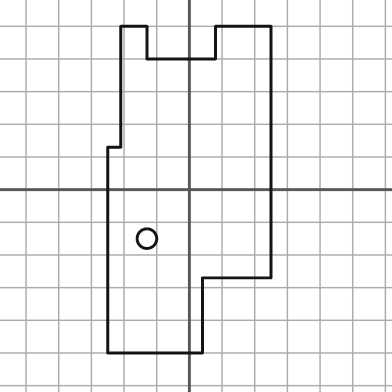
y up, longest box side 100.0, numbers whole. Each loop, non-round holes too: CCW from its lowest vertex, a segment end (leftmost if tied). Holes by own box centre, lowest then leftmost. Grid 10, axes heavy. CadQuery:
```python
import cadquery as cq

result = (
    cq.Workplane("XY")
    .moveTo(-25.0, -50.0)
    .lineTo(4.0, -50.0)
    .lineTo(4.0, -27.0)
    .lineTo(25.0, -27.0)
    .lineTo(25.0, 50.0)
    .lineTo(8.0, 50.0)
    .lineTo(8.0, 40.0)
    .lineTo(-13.0, 40.0)
    .lineTo(-13.0, 50.0)
    .lineTo(-21.0, 50.0)
    .lineTo(-21.0, 13.0)
    .lineTo(-25.0, 13.0)
    .close()
    .moveTo(-13.0, -15.0)
    .circle(3.0)
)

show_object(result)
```